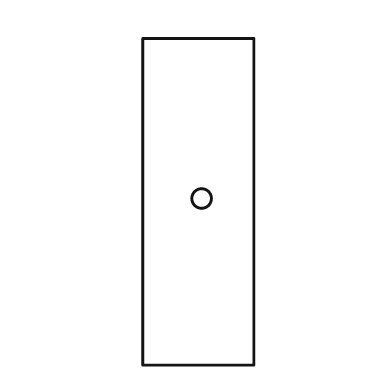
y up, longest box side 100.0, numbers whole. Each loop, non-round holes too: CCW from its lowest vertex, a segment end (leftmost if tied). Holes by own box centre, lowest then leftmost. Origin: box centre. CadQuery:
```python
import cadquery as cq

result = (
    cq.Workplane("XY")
    .moveTo(-17.0, -50.0)
    .lineTo(17.0, -50.0)
    .lineTo(17.0, 50.0)
    .lineTo(-17.0, 50.0)
    .close()
    .moveTo(1.0, 1.0)
    .circle(3.0)
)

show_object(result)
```